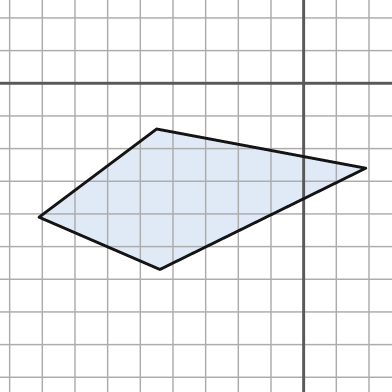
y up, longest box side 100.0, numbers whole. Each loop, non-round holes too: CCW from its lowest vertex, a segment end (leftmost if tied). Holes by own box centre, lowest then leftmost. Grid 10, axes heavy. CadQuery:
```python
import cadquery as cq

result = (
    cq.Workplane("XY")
    .moveTo(-44.0, -57.0)
    .lineTo(19.0, -26.0)
    .lineTo(-45.0, -14.0)
    .lineTo(-81.0, -41.0)
    .close()
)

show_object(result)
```